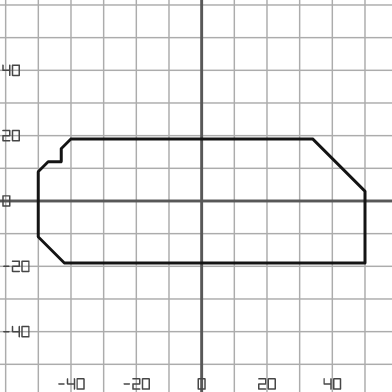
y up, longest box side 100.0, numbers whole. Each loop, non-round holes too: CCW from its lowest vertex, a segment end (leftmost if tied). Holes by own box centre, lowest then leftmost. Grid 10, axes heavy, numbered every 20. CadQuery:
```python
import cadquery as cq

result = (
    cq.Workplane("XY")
    .moveTo(-42.0, -19.0)
    .lineTo(50.0, -19.0)
    .lineTo(50.0, 3.0)
    .lineTo(34.0, 19.0)
    .lineTo(-40.0, 19.0)
    .lineTo(-43.0, 16.0)
    .lineTo(-43.0, 12.0)
    .lineTo(-47.0, 12.0)
    .lineTo(-50.0, 9.0)
    .lineTo(-50.0, -11.0)
    .close()
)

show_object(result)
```